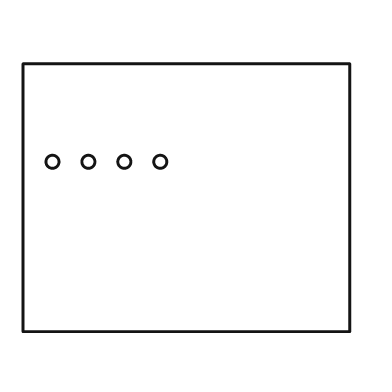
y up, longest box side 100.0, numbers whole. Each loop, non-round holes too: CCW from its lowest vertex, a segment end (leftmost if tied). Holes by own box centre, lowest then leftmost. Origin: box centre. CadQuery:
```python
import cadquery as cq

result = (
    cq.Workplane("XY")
    .moveTo(-50.0, -41.0)
    .lineTo(50.0, -41.0)
    .lineTo(50.0, 41.0)
    .lineTo(-50.0, 41.0)
    .close()
    .moveTo(-41.0, 11.0)
    .circle(2.0)
    .moveTo(-30.0, 11.0)
    .circle(2.0)
    .moveTo(-19.0, 11.0)
    .circle(2.0)
    .moveTo(-8.0, 11.0)
    .circle(2.0)
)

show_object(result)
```